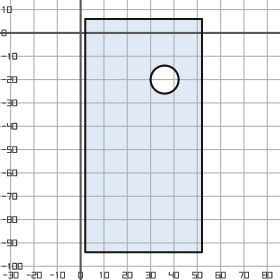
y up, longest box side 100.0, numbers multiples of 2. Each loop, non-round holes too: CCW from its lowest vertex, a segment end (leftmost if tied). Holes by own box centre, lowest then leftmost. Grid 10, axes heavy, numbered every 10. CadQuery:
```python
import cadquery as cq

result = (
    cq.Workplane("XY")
    .moveTo(2.0, -94.0)
    .lineTo(52.0, -94.0)
    .lineTo(52.0, 6.0)
    .lineTo(2.0, 6.0)
    .close()
    .moveTo(36.0, -20.0)
    .circle(6.0)
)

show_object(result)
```